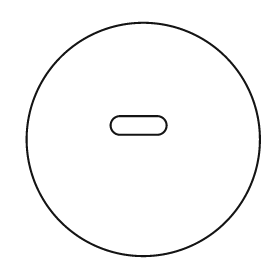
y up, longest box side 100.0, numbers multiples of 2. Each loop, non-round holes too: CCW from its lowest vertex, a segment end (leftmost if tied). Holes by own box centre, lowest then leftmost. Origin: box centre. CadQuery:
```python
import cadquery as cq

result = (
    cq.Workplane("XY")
    .moveTo(0.0, 0.0)
    .circle(50.0)
    .moveTo(-10.0, 2.0)
    .lineTo(6.0, 2.0)
    .threePointArc((10.0, 6.0), (6.0, 10.0))
    .lineTo(-10.0, 10.0)
    .threePointArc((-14.0, 6.0), (-10.0, 2.0))
    .close()
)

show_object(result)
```